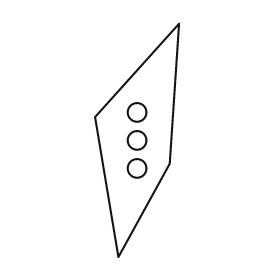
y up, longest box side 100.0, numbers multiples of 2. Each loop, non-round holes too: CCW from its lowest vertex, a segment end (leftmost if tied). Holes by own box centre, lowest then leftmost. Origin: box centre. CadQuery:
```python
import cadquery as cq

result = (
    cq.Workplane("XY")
    .moveTo(-8.0, -50.0)
    .lineTo(14.0, -10.0)
    .lineTo(18.0, 50.0)
    .lineTo(-18.0, 10.0)
    .close()
    .moveTo(0.0, -12.0)
    .circle(4.0)
    .moveTo(0.0, 0.0)
    .circle(4.0)
    .moveTo(0.0, 12.0)
    .circle(4.0)
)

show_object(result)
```